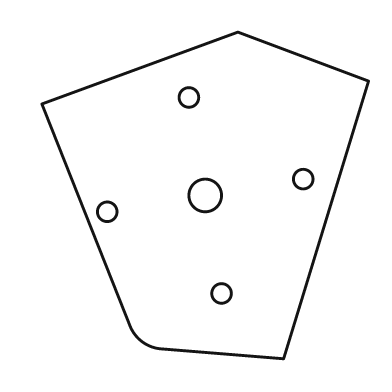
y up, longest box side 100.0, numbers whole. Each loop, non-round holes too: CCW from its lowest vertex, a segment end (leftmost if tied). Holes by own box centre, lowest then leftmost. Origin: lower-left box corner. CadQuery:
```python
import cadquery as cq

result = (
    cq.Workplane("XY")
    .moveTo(74.0, 0.0)
    .lineTo(100.0, 85.0)
    .lineTo(60.0, 100.0)
    .lineTo(0.0, 78.0)
    .lineTo(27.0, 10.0)
    .threePointArc((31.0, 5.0), (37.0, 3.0))
    .close()
    .moveTo(55.0, 20.0)
    .circle(3.0)
    .moveTo(20.0, 45.0)
    .circle(3.0)
    .moveTo(50.0, 50.0)
    .circle(5.0)
    .moveTo(80.0, 55.0)
    .circle(3.0)
    .moveTo(45.0, 80.0)
    .circle(3.0)
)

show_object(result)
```